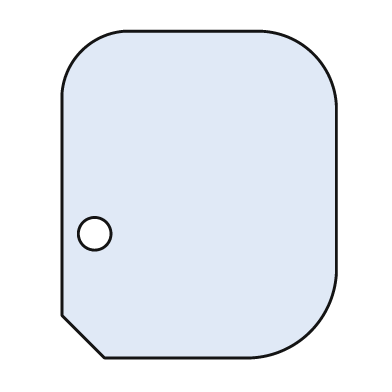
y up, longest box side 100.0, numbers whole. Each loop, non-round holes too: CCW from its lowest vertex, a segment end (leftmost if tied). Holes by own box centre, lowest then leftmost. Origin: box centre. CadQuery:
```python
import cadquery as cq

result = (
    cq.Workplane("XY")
    .moveTo(-29.0, -50.0)
    .lineTo(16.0, -50.0)
    .threePointArc((34.0, -42.0), (42.0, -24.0))
    .lineTo(42.0, 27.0)
    .threePointArc((35.0, 43.0), (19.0, 50.0))
    .lineTo(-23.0, 50.0)
    .threePointArc((-36.0, 44.0), (-42.0, 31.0))
    .lineTo(-42.0, -37.0)
    .close()
    .moveTo(-32.0, -12.0)
    .circle(5.0)
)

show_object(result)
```